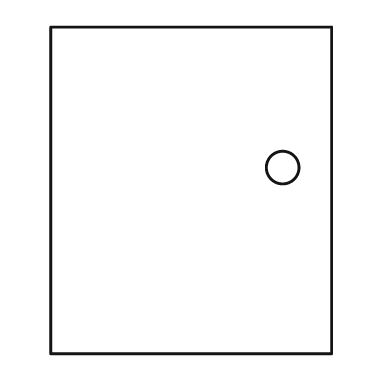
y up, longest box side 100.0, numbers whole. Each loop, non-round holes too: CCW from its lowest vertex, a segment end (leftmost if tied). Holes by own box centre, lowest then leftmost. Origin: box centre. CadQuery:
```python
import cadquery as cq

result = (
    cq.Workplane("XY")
    .moveTo(-43.0, -50.0)
    .lineTo(43.0, -50.0)
    .lineTo(43.0, 50.0)
    .lineTo(-43.0, 50.0)
    .close()
    .moveTo(28.0, 7.0)
    .circle(5.0)
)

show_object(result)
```